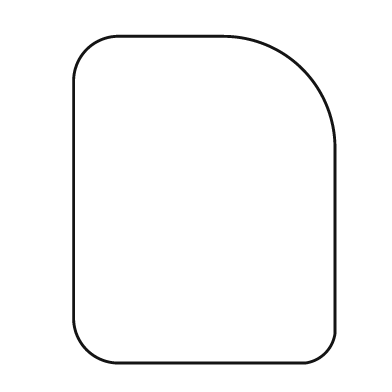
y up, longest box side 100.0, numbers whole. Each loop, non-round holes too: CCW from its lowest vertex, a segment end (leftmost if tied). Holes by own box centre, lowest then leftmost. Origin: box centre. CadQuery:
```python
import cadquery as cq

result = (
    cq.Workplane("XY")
    .moveTo(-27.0, -50.0)
    .lineTo(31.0, -50.0)
    .threePointArc((37.0, -47.0), (40.0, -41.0))
    .lineTo(40.0, 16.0)
    .threePointArc((30.0, 40.0), (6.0, 50.0))
    .lineTo(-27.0, 50.0)
    .threePointArc((-36.0, 46.0), (-40.0, 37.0))
    .lineTo(-40.0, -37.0)
    .threePointArc((-36.0, -46.0), (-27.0, -50.0))
    .close()
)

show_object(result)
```